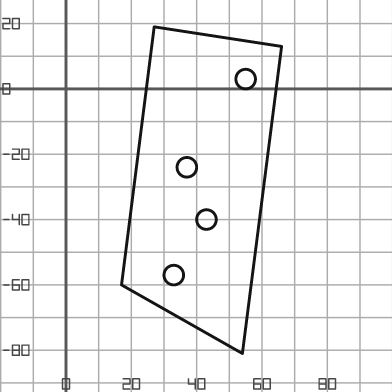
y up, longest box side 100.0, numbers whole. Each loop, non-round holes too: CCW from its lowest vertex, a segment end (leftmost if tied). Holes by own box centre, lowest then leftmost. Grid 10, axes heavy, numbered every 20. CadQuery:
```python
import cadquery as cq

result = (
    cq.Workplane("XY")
    .moveTo(54.0, -81.0)
    .lineTo(66.0, 13.0)
    .lineTo(27.0, 19.0)
    .lineTo(17.0, -60.0)
    .close()
    .moveTo(33.0, -57.0)
    .circle(3.0)
    .moveTo(43.0, -40.0)
    .circle(3.0)
    .moveTo(37.0, -24.0)
    .circle(3.0)
    .moveTo(55.0, 3.0)
    .circle(3.0)
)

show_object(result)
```